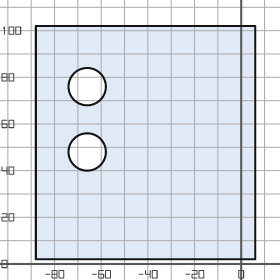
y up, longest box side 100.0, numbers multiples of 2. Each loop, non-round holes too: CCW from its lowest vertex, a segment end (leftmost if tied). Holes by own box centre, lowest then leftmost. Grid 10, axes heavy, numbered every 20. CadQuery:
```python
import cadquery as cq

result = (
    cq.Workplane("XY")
    .moveTo(-88.0, 2.0)
    .lineTo(6.0, 2.0)
    .lineTo(6.0, 102.0)
    .lineTo(-88.0, 102.0)
    .close()
    .moveTo(-66.0, 48.0)
    .circle(8.0)
    .moveTo(-66.0, 76.0)
    .circle(8.0)
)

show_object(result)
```